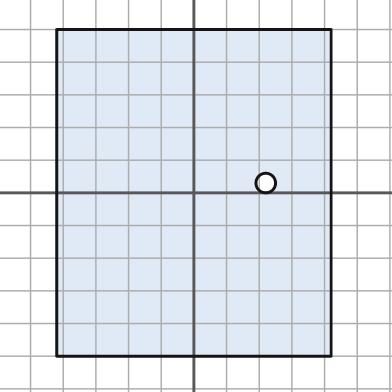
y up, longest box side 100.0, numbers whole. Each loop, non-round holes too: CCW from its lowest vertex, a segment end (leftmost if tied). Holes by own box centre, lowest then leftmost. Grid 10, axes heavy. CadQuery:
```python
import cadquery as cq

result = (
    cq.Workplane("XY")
    .moveTo(-42.0, -50.0)
    .lineTo(42.0, -50.0)
    .lineTo(42.0, 50.0)
    .lineTo(-42.0, 50.0)
    .close()
    .moveTo(22.0, 3.0)
    .circle(3.0)
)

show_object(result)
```